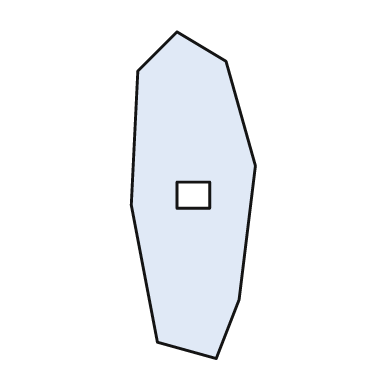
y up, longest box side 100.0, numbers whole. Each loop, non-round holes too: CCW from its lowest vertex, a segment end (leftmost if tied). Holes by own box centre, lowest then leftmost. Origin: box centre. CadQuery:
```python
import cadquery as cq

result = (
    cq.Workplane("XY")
    .moveTo(7.0, -50.0)
    .lineTo(14.0, -32.0)
    .lineTo(19.0, 9.0)
    .lineTo(10.0, 41.0)
    .lineTo(-5.0, 50.0)
    .lineTo(-17.0, 38.0)
    .lineTo(-19.0, -3.0)
    .lineTo(-11.0, -45.0)
    .close()
    .moveTo(-5.0, -4.0)
    .lineTo(5.0, -4.0)
    .lineTo(5.0, 4.0)
    .lineTo(-5.0, 4.0)
    .close()
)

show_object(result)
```